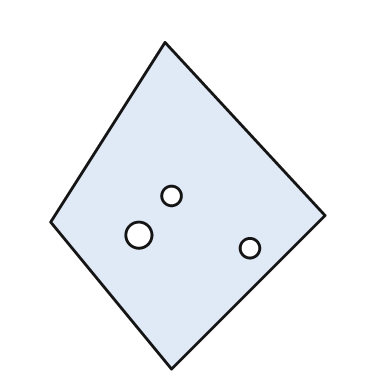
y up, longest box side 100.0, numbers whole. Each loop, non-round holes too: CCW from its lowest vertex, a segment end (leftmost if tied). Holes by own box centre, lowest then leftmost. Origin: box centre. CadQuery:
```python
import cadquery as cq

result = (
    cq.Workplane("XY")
    .moveTo(-5.0, -50.0)
    .lineTo(42.0, -3.0)
    .lineTo(-7.0, 50.0)
    .lineTo(-42.0, -5.0)
    .close()
    .moveTo(19.0, -13.0)
    .circle(3.0)
    .moveTo(-15.0, -9.0)
    .circle(4.0)
    .moveTo(-5.0, 3.0)
    .circle(3.0)
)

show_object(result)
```